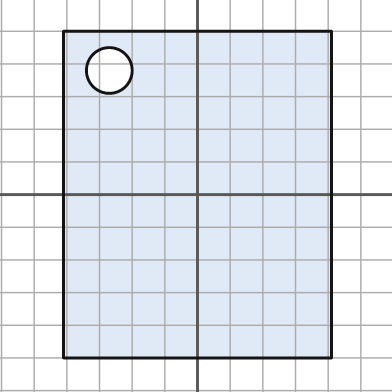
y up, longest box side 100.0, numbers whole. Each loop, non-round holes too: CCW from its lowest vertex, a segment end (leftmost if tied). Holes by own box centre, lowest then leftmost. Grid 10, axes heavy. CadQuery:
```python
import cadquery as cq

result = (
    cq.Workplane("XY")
    .moveTo(-41.0, -50.0)
    .lineTo(41.0, -50.0)
    .lineTo(41.0, 50.0)
    .lineTo(-41.0, 50.0)
    .close()
    .moveTo(-27.0, 38.0)
    .circle(7.0)
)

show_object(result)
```